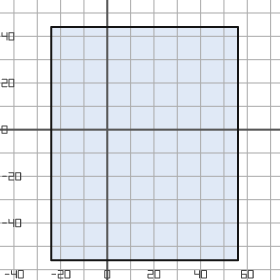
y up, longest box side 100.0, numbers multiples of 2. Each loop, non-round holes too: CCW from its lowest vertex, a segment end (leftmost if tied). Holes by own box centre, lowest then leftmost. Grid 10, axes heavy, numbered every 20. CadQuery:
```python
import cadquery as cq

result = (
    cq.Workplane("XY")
    .moveTo(-24.0, -56.0)
    .lineTo(56.0, -56.0)
    .lineTo(56.0, 44.0)
    .lineTo(-24.0, 44.0)
    .close()
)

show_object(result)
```